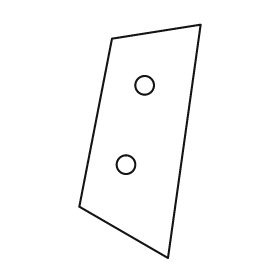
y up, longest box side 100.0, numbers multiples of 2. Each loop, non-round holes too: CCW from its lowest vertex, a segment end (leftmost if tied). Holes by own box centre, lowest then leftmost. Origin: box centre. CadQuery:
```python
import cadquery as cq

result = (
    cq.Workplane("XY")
    .moveTo(12.0, -50.0)
    .lineTo(26.0, 50.0)
    .lineTo(-12.0, 44.0)
    .lineTo(-26.0, -28.0)
    .close()
    .moveTo(-6.0, -10.0)
    .circle(4.0)
    .moveTo(2.0, 24.0)
    .circle(4.0)
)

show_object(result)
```